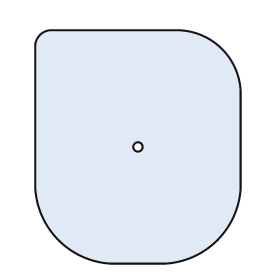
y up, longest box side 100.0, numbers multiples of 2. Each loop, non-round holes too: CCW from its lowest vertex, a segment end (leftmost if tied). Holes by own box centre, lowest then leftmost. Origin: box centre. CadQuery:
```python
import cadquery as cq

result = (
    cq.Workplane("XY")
    .moveTo(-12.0, -50.0)
    .lineTo(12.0, -50.0)
    .threePointArc((34.0, -40.0), (44.0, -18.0))
    .lineTo(44.0, 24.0)
    .threePointArc((36.0, 42.0), (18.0, 50.0))
    .lineTo(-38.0, 50.0)
    .threePointArc((-42.0, 48.0), (-44.0, 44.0))
    .lineTo(-44.0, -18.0)
    .threePointArc((-34.0, -40.0), (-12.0, -50.0))
    .close()
    .moveTo(0.0, 0.0)
    .circle(2.0)
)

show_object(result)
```